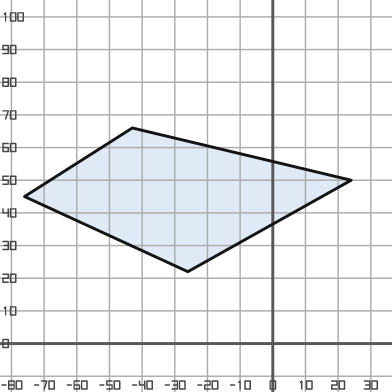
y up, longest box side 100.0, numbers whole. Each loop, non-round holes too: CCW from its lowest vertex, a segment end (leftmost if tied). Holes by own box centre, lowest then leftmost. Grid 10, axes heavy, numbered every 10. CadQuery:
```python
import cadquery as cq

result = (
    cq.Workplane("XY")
    .moveTo(-26.0, 22.0)
    .lineTo(24.0, 50.0)
    .lineTo(-43.0, 66.0)
    .lineTo(-76.0, 45.0)
    .close()
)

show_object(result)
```